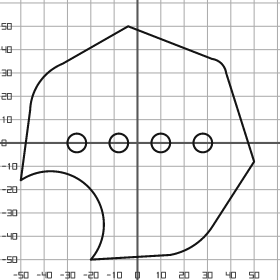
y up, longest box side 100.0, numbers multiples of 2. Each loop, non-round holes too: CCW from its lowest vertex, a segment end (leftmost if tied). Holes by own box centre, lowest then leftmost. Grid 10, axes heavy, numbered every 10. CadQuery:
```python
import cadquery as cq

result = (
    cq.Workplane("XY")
    .moveTo(-20.0, -50.0)
    .lineTo(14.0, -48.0)
    .threePointArc((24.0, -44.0), (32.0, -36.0))
    .lineTo(50.0, -8.0)
    .lineTo(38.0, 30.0)
    .threePointArc((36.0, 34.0), (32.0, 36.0))
    .lineTo(-4.0, 50.0)
    .lineTo(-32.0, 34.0)
    .threePointArc((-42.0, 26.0), (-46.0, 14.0))
    .lineTo(-50.0, -16.0)
    .threePointArc((-20.0, -20.0), (-20.0, -50.0))
    .close()
    .moveTo(-26.0, 0.0)
    .circle(4.0)
    .moveTo(-8.0, 0.0)
    .circle(4.0)
    .moveTo(10.0, 0.0)
    .circle(4.0)
    .moveTo(28.0, 0.0)
    .circle(4.0)
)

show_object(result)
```